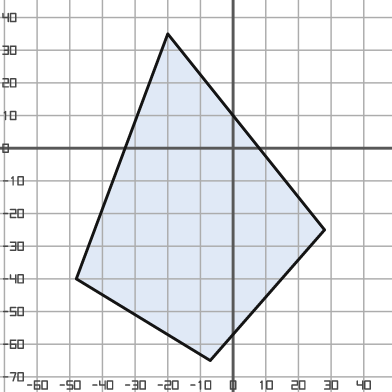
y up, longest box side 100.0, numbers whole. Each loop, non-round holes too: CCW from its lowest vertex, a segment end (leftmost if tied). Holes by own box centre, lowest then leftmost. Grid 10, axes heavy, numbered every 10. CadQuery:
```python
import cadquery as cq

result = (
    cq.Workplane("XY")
    .moveTo(-7.0, -65.0)
    .lineTo(28.0, -25.0)
    .lineTo(-20.0, 35.0)
    .lineTo(-48.0, -40.0)
    .close()
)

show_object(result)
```